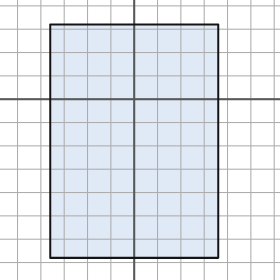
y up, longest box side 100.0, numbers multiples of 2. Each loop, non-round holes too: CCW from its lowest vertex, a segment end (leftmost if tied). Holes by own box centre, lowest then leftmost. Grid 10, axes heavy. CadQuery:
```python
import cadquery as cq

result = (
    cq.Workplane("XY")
    .moveTo(-36.0, -68.0)
    .lineTo(36.0, -68.0)
    .lineTo(36.0, 32.0)
    .lineTo(-36.0, 32.0)
    .close()
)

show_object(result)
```